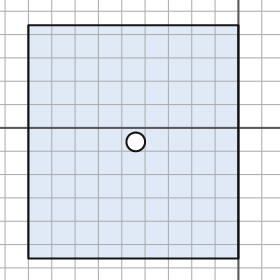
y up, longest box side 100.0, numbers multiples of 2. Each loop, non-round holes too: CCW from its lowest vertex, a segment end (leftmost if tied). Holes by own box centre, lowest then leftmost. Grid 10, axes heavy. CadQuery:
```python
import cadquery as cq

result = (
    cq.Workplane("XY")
    .moveTo(-90.0, -56.0)
    .lineTo(0.0, -56.0)
    .lineTo(0.0, 44.0)
    .lineTo(-90.0, 44.0)
    .close()
    .moveTo(-44.0, -6.0)
    .circle(4.0)
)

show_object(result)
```